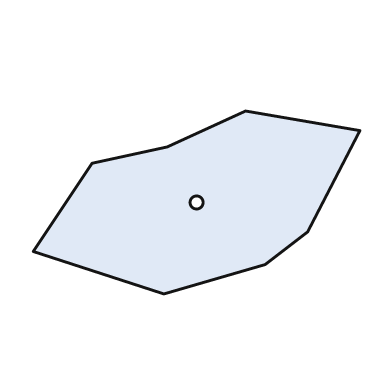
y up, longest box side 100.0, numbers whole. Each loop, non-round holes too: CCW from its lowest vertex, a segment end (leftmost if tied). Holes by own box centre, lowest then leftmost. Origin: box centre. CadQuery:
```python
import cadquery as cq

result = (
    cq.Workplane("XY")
    .moveTo(-10.0, -28.0)
    .lineTo(21.0, -19.0)
    .lineTo(34.0, -9.0)
    .lineTo(50.0, 22.0)
    .lineTo(15.0, 28.0)
    .lineTo(-9.0, 17.0)
    .lineTo(-32.0, 12.0)
    .lineTo(-50.0, -15.0)
    .close()
    .moveTo(0.0, 0.0)
    .circle(2.0)
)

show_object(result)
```